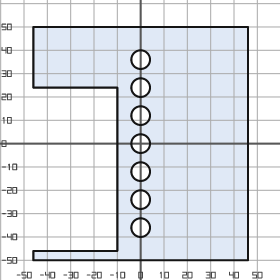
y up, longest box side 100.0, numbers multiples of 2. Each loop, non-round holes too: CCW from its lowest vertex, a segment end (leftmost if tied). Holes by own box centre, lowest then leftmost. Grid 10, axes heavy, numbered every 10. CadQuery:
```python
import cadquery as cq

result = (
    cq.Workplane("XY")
    .moveTo(-46.0, -50.0)
    .lineTo(46.0, -50.0)
    .lineTo(46.0, 50.0)
    .lineTo(-46.0, 50.0)
    .lineTo(-46.0, 24.0)
    .lineTo(-10.0, 24.0)
    .lineTo(-10.0, -46.0)
    .lineTo(-46.0, -46.0)
    .close()
    .moveTo(0.0, -36.0)
    .circle(4.0)
    .moveTo(0.0, -24.0)
    .circle(4.0)
    .moveTo(0.0, -12.0)
    .circle(4.0)
    .moveTo(0.0, 0.0)
    .circle(4.0)
    .moveTo(0.0, 12.0)
    .circle(4.0)
    .moveTo(0.0, 24.0)
    .circle(4.0)
    .moveTo(0.0, 36.0)
    .circle(4.0)
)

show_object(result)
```